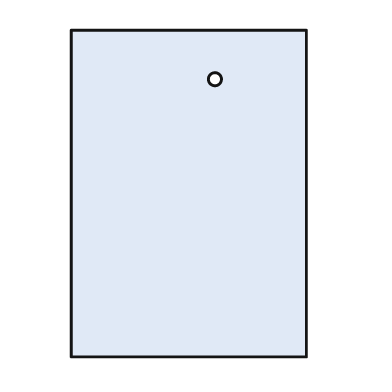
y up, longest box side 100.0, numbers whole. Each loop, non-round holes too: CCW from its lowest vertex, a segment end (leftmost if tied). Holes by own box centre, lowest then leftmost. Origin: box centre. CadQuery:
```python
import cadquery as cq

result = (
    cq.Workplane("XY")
    .moveTo(-36.0, -50.0)
    .lineTo(36.0, -50.0)
    .lineTo(36.0, 50.0)
    .lineTo(-36.0, 50.0)
    .close()
    .moveTo(8.0, 35.0)
    .circle(2.0)
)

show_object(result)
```